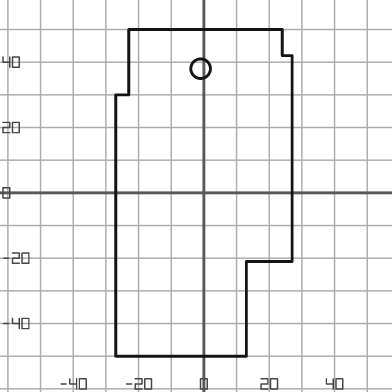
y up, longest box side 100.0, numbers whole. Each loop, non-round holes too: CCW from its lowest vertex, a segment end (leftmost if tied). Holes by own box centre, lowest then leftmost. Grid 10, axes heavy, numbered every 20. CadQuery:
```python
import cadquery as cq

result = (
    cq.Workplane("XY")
    .moveTo(-27.0, -50.0)
    .lineTo(13.0, -50.0)
    .lineTo(13.0, -21.0)
    .lineTo(27.0, -21.0)
    .lineTo(27.0, 42.0)
    .lineTo(24.0, 42.0)
    .lineTo(24.0, 50.0)
    .lineTo(-23.0, 50.0)
    .lineTo(-23.0, 30.0)
    .lineTo(-27.0, 30.0)
    .close()
    .moveTo(-1.0, 38.0)
    .circle(3.0)
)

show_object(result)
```